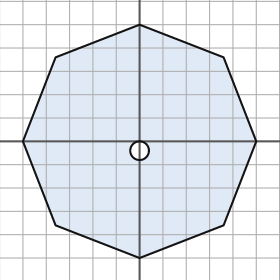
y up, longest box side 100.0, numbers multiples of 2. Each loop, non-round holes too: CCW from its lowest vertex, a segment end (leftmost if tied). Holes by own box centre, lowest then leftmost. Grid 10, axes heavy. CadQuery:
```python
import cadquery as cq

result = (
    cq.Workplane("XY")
    .moveTo(0.0, -50.0)
    .lineTo(36.0, -36.0)
    .lineTo(50.0, 0.0)
    .lineTo(36.0, 36.0)
    .lineTo(0.0, 50.0)
    .lineTo(-36.0, 36.0)
    .lineTo(-50.0, 0.0)
    .lineTo(-36.0, -36.0)
    .close()
    .moveTo(0.0, -4.0)
    .circle(4.0)
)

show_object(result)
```